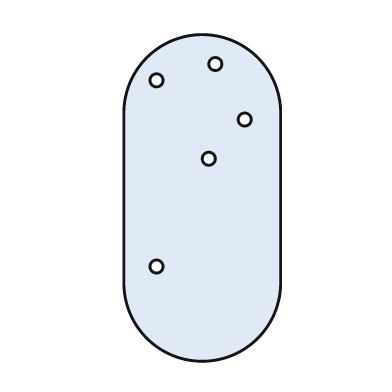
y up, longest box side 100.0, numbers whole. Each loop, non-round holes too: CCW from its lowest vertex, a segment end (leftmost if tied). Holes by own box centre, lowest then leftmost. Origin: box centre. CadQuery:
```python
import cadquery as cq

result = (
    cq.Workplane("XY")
    .moveTo(-24.0, -26.0)
    .threePointArc((0.0, -50.0), (24.0, -26.0))
    .lineTo(24.0, 26.0)
    .threePointArc((0.0, 50.0), (-24.0, 26.0))
    .close()
    .moveTo(-14.0, -21.0)
    .circle(2.0)
    .moveTo(2.0, 12.0)
    .circle(2.0)
    .moveTo(13.0, 24.0)
    .circle(2.0)
    .moveTo(-14.0, 36.0)
    .circle(2.0)
    .moveTo(4.0, 41.0)
    .circle(2.0)
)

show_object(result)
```